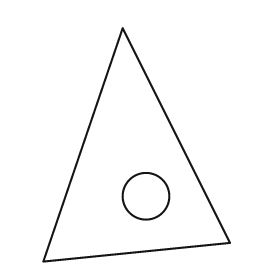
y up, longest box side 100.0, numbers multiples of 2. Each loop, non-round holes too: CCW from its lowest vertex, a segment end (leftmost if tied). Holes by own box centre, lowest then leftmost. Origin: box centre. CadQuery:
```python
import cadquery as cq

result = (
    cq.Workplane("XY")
    .moveTo(-40.0, -50.0)
    .lineTo(40.0, -42.0)
    .lineTo(-6.0, 50.0)
    .close()
    .moveTo(4.0, -22.0)
    .circle(10.0)
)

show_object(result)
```